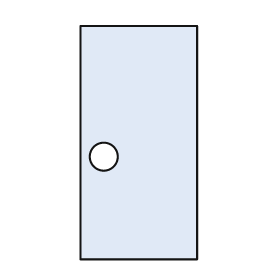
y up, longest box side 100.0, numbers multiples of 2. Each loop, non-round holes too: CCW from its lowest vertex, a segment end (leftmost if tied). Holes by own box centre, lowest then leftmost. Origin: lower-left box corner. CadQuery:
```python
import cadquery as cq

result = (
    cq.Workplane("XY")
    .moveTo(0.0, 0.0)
    .lineTo(50.0, 0.0)
    .lineTo(50.0, 100.0)
    .lineTo(0.0, 100.0)
    .close()
    .moveTo(10.0, 44.0)
    .circle(6.0)
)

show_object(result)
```